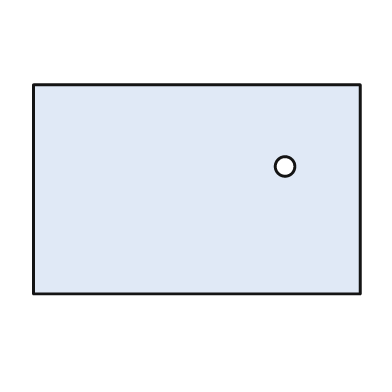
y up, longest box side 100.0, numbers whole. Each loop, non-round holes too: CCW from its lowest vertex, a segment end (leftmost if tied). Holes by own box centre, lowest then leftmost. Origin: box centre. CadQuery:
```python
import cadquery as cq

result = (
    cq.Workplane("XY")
    .moveTo(-50.0, -32.0)
    .lineTo(50.0, -32.0)
    .lineTo(50.0, 32.0)
    .lineTo(-50.0, 32.0)
    .close()
    .moveTo(27.0, 7.0)
    .circle(3.0)
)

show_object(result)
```